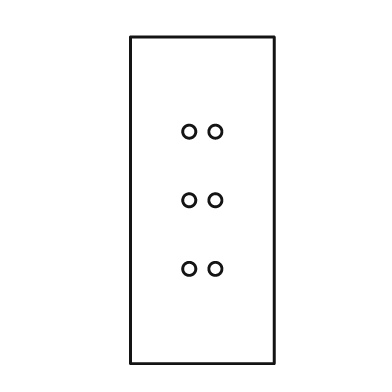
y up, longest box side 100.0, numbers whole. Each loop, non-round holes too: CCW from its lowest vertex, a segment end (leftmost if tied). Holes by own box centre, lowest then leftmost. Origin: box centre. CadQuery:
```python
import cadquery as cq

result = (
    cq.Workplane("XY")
    .moveTo(-22.0, -50.0)
    .lineTo(22.0, -50.0)
    .lineTo(22.0, 50.0)
    .lineTo(-22.0, 50.0)
    .close()
    .moveTo(-4.0, -21.0)
    .circle(2.0)
    .moveTo(4.0, -21.0)
    .circle(2.0)
    .moveTo(-4.0, 0.0)
    .circle(2.0)
    .moveTo(4.0, 0.0)
    .circle(2.0)
    .moveTo(-4.0, 21.0)
    .circle(2.0)
    .moveTo(4.0, 21.0)
    .circle(2.0)
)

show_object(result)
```